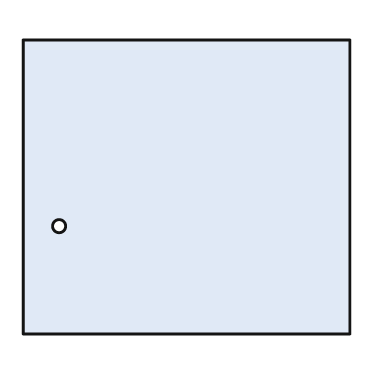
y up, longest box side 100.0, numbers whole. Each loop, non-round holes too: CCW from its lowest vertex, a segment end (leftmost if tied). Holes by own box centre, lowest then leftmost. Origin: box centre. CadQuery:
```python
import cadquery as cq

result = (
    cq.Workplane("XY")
    .moveTo(-50.0, -45.0)
    .lineTo(50.0, -45.0)
    .lineTo(50.0, 45.0)
    .lineTo(-50.0, 45.0)
    .close()
    .moveTo(-39.0, -12.0)
    .circle(2.0)
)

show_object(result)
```